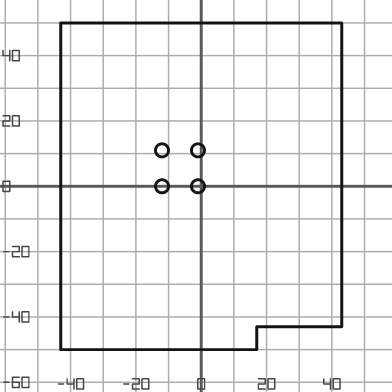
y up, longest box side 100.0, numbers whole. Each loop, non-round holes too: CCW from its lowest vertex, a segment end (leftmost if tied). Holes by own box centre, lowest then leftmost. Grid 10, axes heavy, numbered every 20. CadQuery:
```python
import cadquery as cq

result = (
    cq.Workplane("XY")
    .moveTo(-43.0, -50.0)
    .lineTo(17.0, -50.0)
    .lineTo(17.0, -43.0)
    .lineTo(43.0, -43.0)
    .lineTo(43.0, 50.0)
    .lineTo(-43.0, 50.0)
    .close()
    .moveTo(-12.0, 0.0)
    .circle(2.0)
    .moveTo(-1.0, 0.0)
    .circle(2.0)
    .moveTo(-12.0, 11.0)
    .circle(2.0)
    .moveTo(-1.0, 11.0)
    .circle(2.0)
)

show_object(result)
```